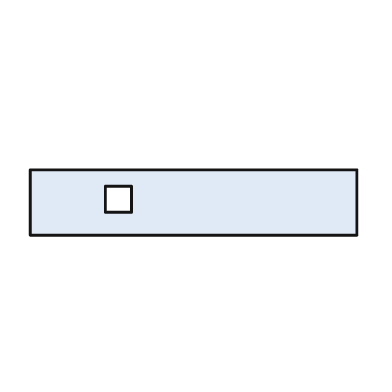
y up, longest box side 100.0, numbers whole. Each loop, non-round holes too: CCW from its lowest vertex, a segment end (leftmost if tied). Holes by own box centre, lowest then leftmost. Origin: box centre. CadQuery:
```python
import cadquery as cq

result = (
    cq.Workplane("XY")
    .moveTo(-50.0, -10.0)
    .lineTo(50.0, -10.0)
    .lineTo(50.0, 10.0)
    .lineTo(-50.0, 10.0)
    .close()
    .moveTo(-27.0, -3.0)
    .lineTo(-19.0, -3.0)
    .lineTo(-19.0, 5.0)
    .lineTo(-27.0, 5.0)
    .close()
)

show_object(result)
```